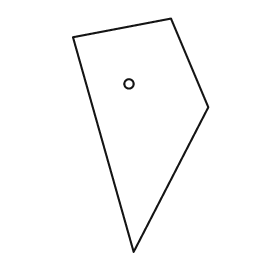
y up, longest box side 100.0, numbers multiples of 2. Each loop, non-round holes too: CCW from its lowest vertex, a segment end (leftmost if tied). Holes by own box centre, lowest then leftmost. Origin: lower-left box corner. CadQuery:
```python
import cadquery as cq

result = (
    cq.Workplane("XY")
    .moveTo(26.0, 0.0)
    .lineTo(58.0, 62.0)
    .lineTo(42.0, 100.0)
    .lineTo(0.0, 92.0)
    .close()
    .moveTo(24.0, 72.0)
    .circle(2.0)
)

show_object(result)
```